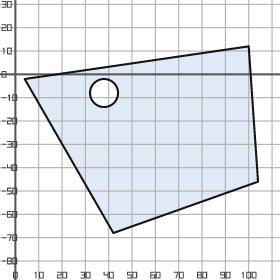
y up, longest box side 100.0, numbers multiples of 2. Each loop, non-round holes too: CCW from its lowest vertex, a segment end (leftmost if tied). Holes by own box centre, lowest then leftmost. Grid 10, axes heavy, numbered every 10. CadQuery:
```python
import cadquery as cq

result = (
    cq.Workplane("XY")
    .moveTo(42.0, -68.0)
    .lineTo(104.0, -46.0)
    .lineTo(100.0, 12.0)
    .lineTo(4.0, -2.0)
    .close()
    .moveTo(38.0, -8.0)
    .circle(6.0)
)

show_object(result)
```